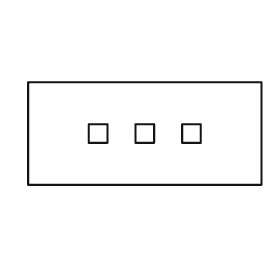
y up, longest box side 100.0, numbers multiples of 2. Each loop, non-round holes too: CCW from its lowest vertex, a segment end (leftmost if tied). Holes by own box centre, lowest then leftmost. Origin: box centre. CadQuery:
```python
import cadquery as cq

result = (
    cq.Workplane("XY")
    .moveTo(-50.0, -22.0)
    .lineTo(50.0, -22.0)
    .lineTo(50.0, 22.0)
    .lineTo(-50.0, 22.0)
    .close()
    .moveTo(-24.0, -4.0)
    .lineTo(-16.0, -4.0)
    .lineTo(-16.0, 4.0)
    .lineTo(-24.0, 4.0)
    .close()
    .moveTo(-4.0, -4.0)
    .lineTo(4.0, -4.0)
    .lineTo(4.0, 4.0)
    .lineTo(-4.0, 4.0)
    .close()
    .moveTo(16.0, -4.0)
    .lineTo(24.0, -4.0)
    .lineTo(24.0, 4.0)
    .lineTo(16.0, 4.0)
    .close()
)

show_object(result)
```